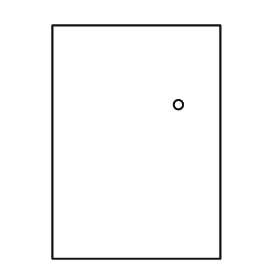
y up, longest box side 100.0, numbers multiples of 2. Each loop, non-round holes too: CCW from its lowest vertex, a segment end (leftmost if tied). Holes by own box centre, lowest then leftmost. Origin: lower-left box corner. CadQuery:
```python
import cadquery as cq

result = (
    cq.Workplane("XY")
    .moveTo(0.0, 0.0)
    .lineTo(72.0, 0.0)
    .lineTo(72.0, 100.0)
    .lineTo(0.0, 100.0)
    .close()
    .moveTo(54.0, 66.0)
    .circle(2.0)
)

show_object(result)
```